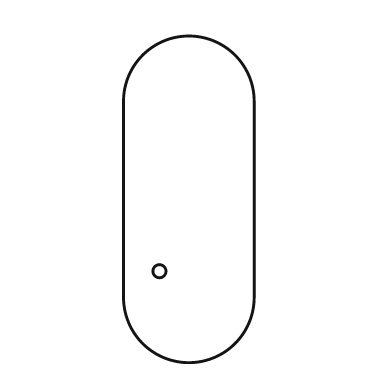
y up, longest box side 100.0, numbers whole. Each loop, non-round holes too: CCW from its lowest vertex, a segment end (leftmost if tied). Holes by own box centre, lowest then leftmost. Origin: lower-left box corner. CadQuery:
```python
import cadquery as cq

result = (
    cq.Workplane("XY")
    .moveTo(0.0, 20.0)
    .threePointArc((20.0, 0.0), (40.0, 20.0))
    .lineTo(40.0, 80.0)
    .threePointArc((20.0, 100.0), (0.0, 80.0))
    .close()
    .moveTo(11.0, 28.0)
    .circle(2.0)
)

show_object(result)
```